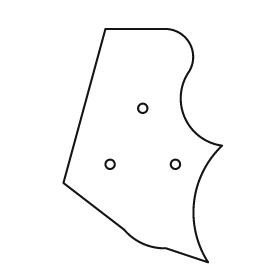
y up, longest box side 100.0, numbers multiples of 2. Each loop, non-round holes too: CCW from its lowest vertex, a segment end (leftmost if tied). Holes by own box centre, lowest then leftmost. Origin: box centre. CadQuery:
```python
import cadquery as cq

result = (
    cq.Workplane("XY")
    .moveTo(28.0, -50.0)
    .threePointArc((22.0, -24.0), (34.0, 0.0))
    .threePointArc((18.0, 12.0), (20.0, 32.0))
    .threePointArc((20.0, 44.0), (10.0, 50.0))
    .lineTo(-16.0, 50.0)
    .lineTo(-34.0, -16.0)
    .lineTo(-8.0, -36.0)
    .threePointArc((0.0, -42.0), (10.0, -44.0))
    .close()
    .moveTo(-14.0, -8.0)
    .circle(2.0)
    .moveTo(14.0, -8.0)
    .circle(2.0)
    .moveTo(0.0, 16.0)
    .circle(2.0)
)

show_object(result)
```